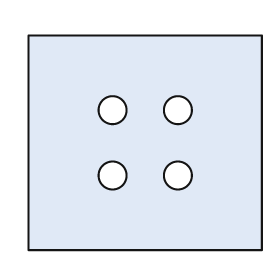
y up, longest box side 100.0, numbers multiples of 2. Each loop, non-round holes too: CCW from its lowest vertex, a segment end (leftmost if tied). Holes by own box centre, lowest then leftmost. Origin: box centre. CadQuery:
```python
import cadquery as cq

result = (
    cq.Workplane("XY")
    .moveTo(-50.0, -46.0)
    .lineTo(50.0, -46.0)
    .lineTo(50.0, 46.0)
    .lineTo(-50.0, 46.0)
    .close()
    .moveTo(-14.0, -14.0)
    .circle(6.0)
    .moveTo(14.0, -14.0)
    .circle(6.0)
    .moveTo(-14.0, 14.0)
    .circle(6.0)
    .moveTo(14.0, 14.0)
    .circle(6.0)
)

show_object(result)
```